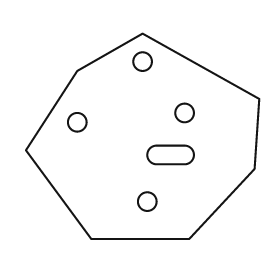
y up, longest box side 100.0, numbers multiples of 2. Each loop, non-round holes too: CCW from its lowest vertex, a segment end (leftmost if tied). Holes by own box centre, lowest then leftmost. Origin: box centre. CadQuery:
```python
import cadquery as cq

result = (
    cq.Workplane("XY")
    .moveTo(-22.0, -44.0)
    .lineTo(20.0, -44.0)
    .lineTo(48.0, -14.0)
    .lineTo(50.0, 16.0)
    .lineTo(0.0, 44.0)
    .lineTo(-28.0, 28.0)
    .lineTo(-50.0, -6.0)
    .close()
    .moveTo(2.0, -28.0)
    .circle(4.0)
    .moveTo(6.0, -12.0)
    .lineTo(18.0, -12.0)
    .threePointArc((22.0, -8.0), (18.0, -4.0))
    .lineTo(6.0, -4.0)
    .threePointArc((2.0, -8.0), (6.0, -12.0))
    .close()
    .moveTo(-28.0, 6.0)
    .circle(4.0)
    .moveTo(18.0, 10.0)
    .circle(4.0)
    .moveTo(0.0, 32.0)
    .circle(4.0)
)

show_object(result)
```